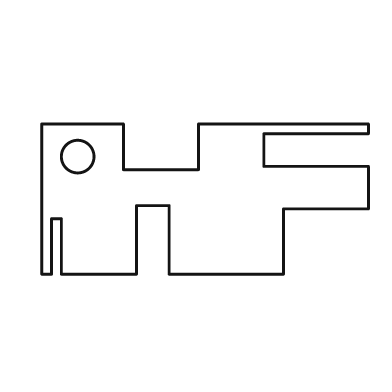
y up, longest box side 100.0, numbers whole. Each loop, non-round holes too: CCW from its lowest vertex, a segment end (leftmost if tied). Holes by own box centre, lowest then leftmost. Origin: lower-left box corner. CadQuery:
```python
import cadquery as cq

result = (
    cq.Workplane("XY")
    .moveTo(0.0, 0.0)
    .lineTo(3.0, 0.0)
    .lineTo(3.0, 17.0)
    .lineTo(6.0, 17.0)
    .lineTo(6.0, 0.0)
    .lineTo(29.0, 0.0)
    .lineTo(29.0, 21.0)
    .lineTo(39.0, 21.0)
    .lineTo(39.0, 0.0)
    .lineTo(74.0, 0.0)
    .lineTo(74.0, 20.0)
    .lineTo(100.0, 20.0)
    .lineTo(100.0, 33.0)
    .lineTo(68.0, 33.0)
    .lineTo(68.0, 43.0)
    .lineTo(100.0, 43.0)
    .lineTo(100.0, 46.0)
    .lineTo(48.0, 46.0)
    .lineTo(48.0, 32.0)
    .lineTo(25.0, 32.0)
    .lineTo(25.0, 46.0)
    .lineTo(0.0, 46.0)
    .close()
    .moveTo(11.0, 36.0)
    .circle(5.0)
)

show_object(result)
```